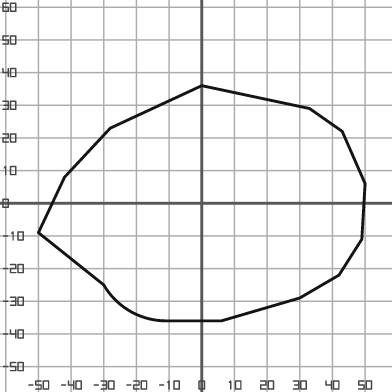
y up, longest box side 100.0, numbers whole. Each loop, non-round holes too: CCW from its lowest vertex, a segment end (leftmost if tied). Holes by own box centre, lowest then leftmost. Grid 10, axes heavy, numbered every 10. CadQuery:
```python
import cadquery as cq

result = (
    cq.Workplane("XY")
    .moveTo(-11.0, -36.0)
    .lineTo(6.0, -36.0)
    .lineTo(30.0, -29.0)
    .lineTo(42.0, -22.0)
    .lineTo(49.0, -11.0)
    .lineTo(50.0, 6.0)
    .lineTo(43.0, 22.0)
    .lineTo(33.0, 29.0)
    .lineTo(0.0, 36.0)
    .lineTo(-28.0, 23.0)
    .lineTo(-42.0, 8.0)
    .lineTo(-50.0, -9.0)
    .lineTo(-30.0, -25.0)
    .threePointArc((-22.0, -33.0), (-11.0, -36.0))
    .close()
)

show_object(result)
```